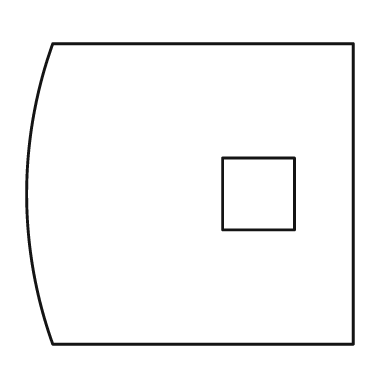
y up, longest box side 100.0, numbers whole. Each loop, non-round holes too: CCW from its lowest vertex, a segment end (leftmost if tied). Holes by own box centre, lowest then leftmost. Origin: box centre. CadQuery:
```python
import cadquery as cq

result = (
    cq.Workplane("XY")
    .moveTo(-42.0, -46.0)
    .lineTo(50.0, -46.0)
    .lineTo(50.0, 46.0)
    .lineTo(-42.0, 46.0)
    .threePointArc((-50.0, 0.0), (-42.0, -46.0))
    .close()
    .moveTo(10.0, -11.0)
    .lineTo(32.0, -11.0)
    .lineTo(32.0, 11.0)
    .lineTo(10.0, 11.0)
    .close()
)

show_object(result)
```